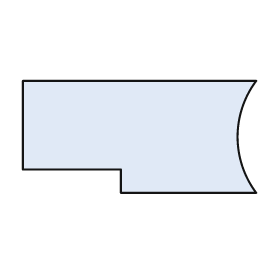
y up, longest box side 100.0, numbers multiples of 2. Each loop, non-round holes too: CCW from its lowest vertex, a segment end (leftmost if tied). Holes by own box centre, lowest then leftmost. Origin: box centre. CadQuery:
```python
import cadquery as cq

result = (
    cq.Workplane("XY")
    .moveTo(-8.0, -24.0)
    .lineTo(50.0, -24.0)
    .threePointArc((42.0, 0.0), (50.0, 24.0))
    .lineTo(-50.0, 24.0)
    .lineTo(-50.0, -14.0)
    .lineTo(-8.0, -14.0)
    .close()
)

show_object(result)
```